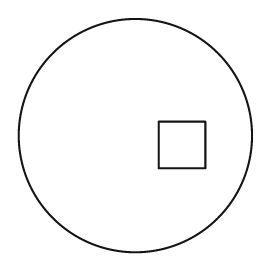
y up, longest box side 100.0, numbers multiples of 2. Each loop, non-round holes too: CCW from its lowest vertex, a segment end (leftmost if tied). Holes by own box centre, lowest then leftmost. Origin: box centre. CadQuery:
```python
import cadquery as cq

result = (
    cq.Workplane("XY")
    .moveTo(0.0, 0.0)
    .circle(50.0)
    .moveTo(10.0, -14.0)
    .lineTo(30.0, -14.0)
    .lineTo(30.0, 6.0)
    .lineTo(10.0, 6.0)
    .close()
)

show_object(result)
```